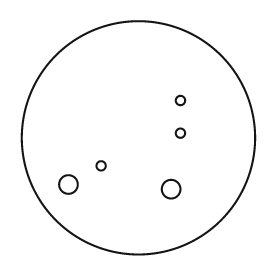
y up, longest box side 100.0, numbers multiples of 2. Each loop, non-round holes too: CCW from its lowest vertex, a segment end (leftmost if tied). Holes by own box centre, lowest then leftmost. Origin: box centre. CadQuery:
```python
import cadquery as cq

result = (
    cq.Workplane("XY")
    .moveTo(0.0, 0.0)
    .circle(50.0)
    .moveTo(14.0, -22.0)
    .circle(4.0)
    .moveTo(-30.0, -20.0)
    .circle(4.0)
    .moveTo(-16.0, -12.0)
    .circle(2.0)
    .moveTo(18.0, 2.0)
    .circle(2.0)
    .moveTo(18.0, 16.0)
    .circle(2.0)
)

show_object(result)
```